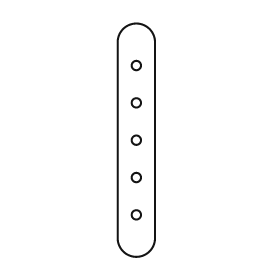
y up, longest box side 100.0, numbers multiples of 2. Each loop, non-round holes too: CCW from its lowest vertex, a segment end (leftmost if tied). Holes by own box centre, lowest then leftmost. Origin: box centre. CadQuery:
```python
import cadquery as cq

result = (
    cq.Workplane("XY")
    .moveTo(-8.0, -42.0)
    .threePointArc((0.0, -50.0), (8.0, -42.0))
    .lineTo(8.0, 42.0)
    .threePointArc((0.0, 50.0), (-8.0, 42.0))
    .close()
    .moveTo(0.0, -32.0)
    .circle(2.0)
    .moveTo(0.0, -16.0)
    .circle(2.0)
    .moveTo(0.0, 0.0)
    .circle(2.0)
    .moveTo(0.0, 16.0)
    .circle(2.0)
    .moveTo(0.0, 32.0)
    .circle(2.0)
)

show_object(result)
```